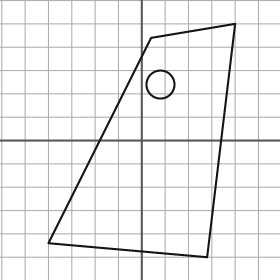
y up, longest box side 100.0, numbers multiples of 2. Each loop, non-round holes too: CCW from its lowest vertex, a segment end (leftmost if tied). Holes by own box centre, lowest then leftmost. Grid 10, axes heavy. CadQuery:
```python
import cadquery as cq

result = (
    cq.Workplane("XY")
    .moveTo(28.0, -50.0)
    .lineTo(40.0, 50.0)
    .lineTo(4.0, 44.0)
    .lineTo(-40.0, -44.0)
    .close()
    .moveTo(8.0, 24.0)
    .circle(6.0)
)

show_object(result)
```